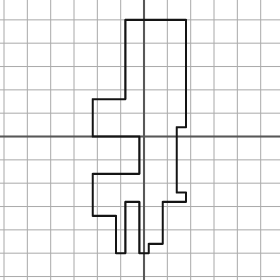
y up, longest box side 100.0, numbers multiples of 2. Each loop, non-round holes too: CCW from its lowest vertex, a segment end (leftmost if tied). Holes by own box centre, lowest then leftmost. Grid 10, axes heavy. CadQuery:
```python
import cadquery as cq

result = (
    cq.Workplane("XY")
    .moveTo(-12.0, -50.0)
    .lineTo(-8.0, -50.0)
    .lineTo(-8.0, -28.0)
    .lineTo(-2.0, -28.0)
    .lineTo(-2.0, -50.0)
    .lineTo(2.0, -50.0)
    .lineTo(2.0, -46.0)
    .lineTo(8.0, -46.0)
    .lineTo(8.0, -28.0)
    .lineTo(18.0, -28.0)
    .lineTo(18.0, -24.0)
    .lineTo(14.0, -24.0)
    .lineTo(14.0, 4.0)
    .lineTo(18.0, 4.0)
    .lineTo(18.0, 50.0)
    .lineTo(-8.0, 50.0)
    .lineTo(-8.0, 16.0)
    .lineTo(-22.0, 16.0)
    .lineTo(-22.0, 0.0)
    .lineTo(-2.0, 0.0)
    .lineTo(-2.0, -16.0)
    .lineTo(-22.0, -16.0)
    .lineTo(-22.0, -34.0)
    .lineTo(-12.0, -34.0)
    .close()
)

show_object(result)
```